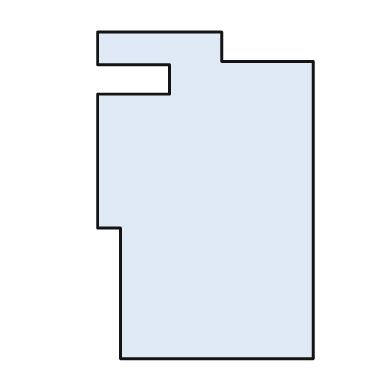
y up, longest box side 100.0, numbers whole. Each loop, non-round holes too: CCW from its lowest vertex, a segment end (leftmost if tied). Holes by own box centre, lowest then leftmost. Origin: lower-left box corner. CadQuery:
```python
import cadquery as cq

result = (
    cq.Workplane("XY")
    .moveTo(7.0, 0.0)
    .lineTo(66.0, 0.0)
    .lineTo(66.0, 91.0)
    .lineTo(38.0, 91.0)
    .lineTo(38.0, 100.0)
    .lineTo(0.0, 100.0)
    .lineTo(0.0, 90.0)
    .lineTo(22.0, 90.0)
    .lineTo(22.0, 81.0)
    .lineTo(0.0, 81.0)
    .lineTo(0.0, 40.0)
    .lineTo(7.0, 40.0)
    .close()
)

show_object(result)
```